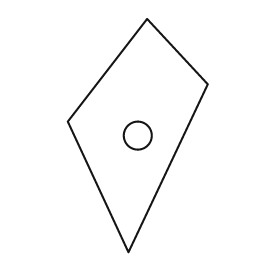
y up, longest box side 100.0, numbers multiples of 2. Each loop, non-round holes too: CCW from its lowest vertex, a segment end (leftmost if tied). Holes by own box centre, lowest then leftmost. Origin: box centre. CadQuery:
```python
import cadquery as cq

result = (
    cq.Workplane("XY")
    .moveTo(-4.0, -50.0)
    .lineTo(30.0, 22.0)
    .lineTo(4.0, 50.0)
    .lineTo(-30.0, 6.0)
    .close()
    .moveTo(0.0, 0.0)
    .circle(6.0)
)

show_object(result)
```